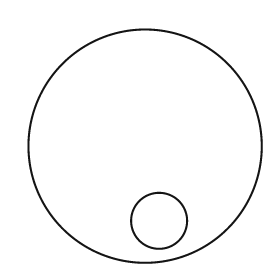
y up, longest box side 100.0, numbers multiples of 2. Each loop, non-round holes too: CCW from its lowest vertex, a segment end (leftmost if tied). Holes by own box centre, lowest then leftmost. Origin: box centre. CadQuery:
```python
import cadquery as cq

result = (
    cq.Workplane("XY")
    .moveTo(0.0, 0.0)
    .circle(50.0)
    .moveTo(6.0, -32.0)
    .circle(12.0)
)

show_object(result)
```